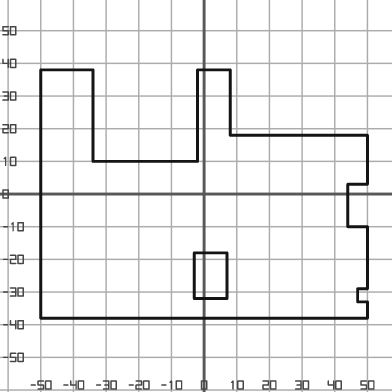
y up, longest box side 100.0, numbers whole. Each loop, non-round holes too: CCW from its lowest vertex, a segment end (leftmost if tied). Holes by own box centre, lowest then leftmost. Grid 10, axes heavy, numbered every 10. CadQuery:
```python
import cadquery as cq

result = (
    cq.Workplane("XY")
    .moveTo(-50.0, -38.0)
    .lineTo(50.0, -38.0)
    .lineTo(50.0, -33.0)
    .lineTo(47.0, -33.0)
    .lineTo(47.0, -29.0)
    .lineTo(50.0, -29.0)
    .lineTo(50.0, -10.0)
    .lineTo(44.0, -10.0)
    .lineTo(44.0, 3.0)
    .lineTo(50.0, 3.0)
    .lineTo(50.0, 18.0)
    .lineTo(8.0, 18.0)
    .lineTo(8.0, 38.0)
    .lineTo(-2.0, 38.0)
    .lineTo(-2.0, 10.0)
    .lineTo(-34.0, 10.0)
    .lineTo(-34.0, 38.0)
    .lineTo(-50.0, 38.0)
    .close()
    .moveTo(-3.0, -32.0)
    .lineTo(7.0, -32.0)
    .lineTo(7.0, -18.0)
    .lineTo(-3.0, -18.0)
    .close()
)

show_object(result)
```